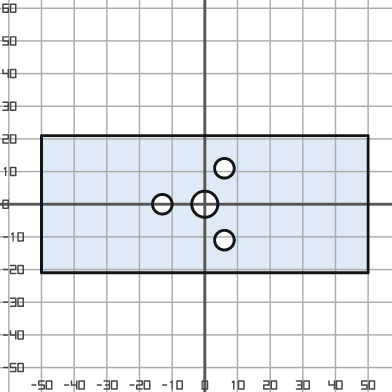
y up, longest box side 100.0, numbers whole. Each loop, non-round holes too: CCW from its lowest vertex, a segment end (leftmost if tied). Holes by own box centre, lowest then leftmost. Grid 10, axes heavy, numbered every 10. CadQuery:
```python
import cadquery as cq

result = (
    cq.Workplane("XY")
    .moveTo(-50.0, -21.0)
    .lineTo(50.0, -21.0)
    .lineTo(50.0, 21.0)
    .lineTo(-50.0, 21.0)
    .close()
    .moveTo(6.0, -11.0)
    .circle(3.0)
    .moveTo(-13.0, 0.0)
    .circle(3.0)
    .moveTo(0.0, 0.0)
    .circle(4.0)
    .moveTo(6.0, 11.0)
    .circle(3.0)
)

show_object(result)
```